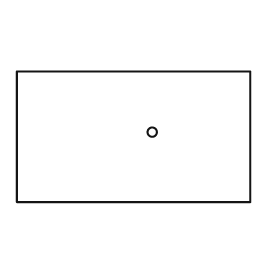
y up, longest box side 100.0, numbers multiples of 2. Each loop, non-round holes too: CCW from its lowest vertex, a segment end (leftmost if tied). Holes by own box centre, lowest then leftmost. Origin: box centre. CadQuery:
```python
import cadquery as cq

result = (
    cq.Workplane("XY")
    .moveTo(-50.0, -28.0)
    .lineTo(50.0, -28.0)
    .lineTo(50.0, 28.0)
    .lineTo(-50.0, 28.0)
    .close()
    .moveTo(8.0, 2.0)
    .circle(2.0)
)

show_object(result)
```